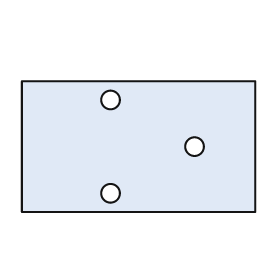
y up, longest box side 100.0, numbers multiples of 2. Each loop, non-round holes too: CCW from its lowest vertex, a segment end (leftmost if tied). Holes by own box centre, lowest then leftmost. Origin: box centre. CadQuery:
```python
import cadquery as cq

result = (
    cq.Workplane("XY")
    .moveTo(-50.0, -28.0)
    .lineTo(50.0, -28.0)
    .lineTo(50.0, 28.0)
    .lineTo(-50.0, 28.0)
    .close()
    .moveTo(-12.0, -20.0)
    .circle(4.0)
    .moveTo(24.0, 0.0)
    .circle(4.0)
    .moveTo(-12.0, 20.0)
    .circle(4.0)
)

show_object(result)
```